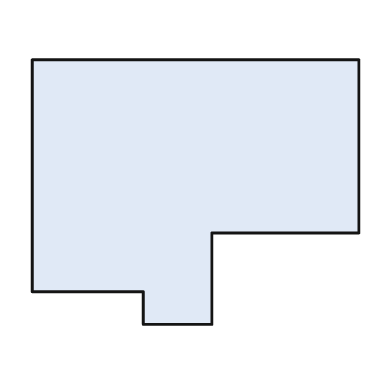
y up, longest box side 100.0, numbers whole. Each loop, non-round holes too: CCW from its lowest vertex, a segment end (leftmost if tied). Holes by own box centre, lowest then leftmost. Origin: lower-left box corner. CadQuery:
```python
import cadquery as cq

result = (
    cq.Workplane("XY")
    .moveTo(34.0, 0.0)
    .lineTo(55.0, 0.0)
    .lineTo(55.0, 28.0)
    .lineTo(100.0, 28.0)
    .lineTo(100.0, 81.0)
    .lineTo(0.0, 81.0)
    .lineTo(0.0, 10.0)
    .lineTo(34.0, 10.0)
    .close()
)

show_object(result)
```